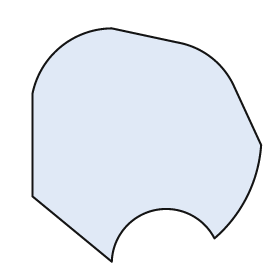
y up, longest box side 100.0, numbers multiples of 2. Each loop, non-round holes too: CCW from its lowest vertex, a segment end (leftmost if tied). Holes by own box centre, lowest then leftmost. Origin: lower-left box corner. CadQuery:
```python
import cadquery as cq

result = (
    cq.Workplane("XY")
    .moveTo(34.0, 0.0)
    .threePointArc((52.0, 22.0), (78.0, 10.0))
    .threePointArc((92.0, 28.0), (98.0, 50.0))
    .lineTo(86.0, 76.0)
    .threePointArc((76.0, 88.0), (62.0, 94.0))
    .lineTo(34.0, 100.0)
    .threePointArc((12.0, 92.0), (0.0, 72.0))
    .lineTo(0.0, 28.0)
    .close()
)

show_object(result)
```